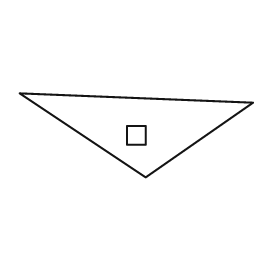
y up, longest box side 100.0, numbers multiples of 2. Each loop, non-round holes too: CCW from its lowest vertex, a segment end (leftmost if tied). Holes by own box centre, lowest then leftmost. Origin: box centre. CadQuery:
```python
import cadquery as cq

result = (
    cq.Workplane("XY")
    .moveTo(4.0, -18.0)
    .lineTo(50.0, 14.0)
    .lineTo(-50.0, 18.0)
    .close()
    .moveTo(-4.0, -4.0)
    .lineTo(4.0, -4.0)
    .lineTo(4.0, 4.0)
    .lineTo(-4.0, 4.0)
    .close()
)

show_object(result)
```